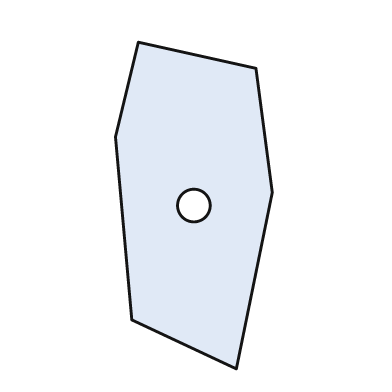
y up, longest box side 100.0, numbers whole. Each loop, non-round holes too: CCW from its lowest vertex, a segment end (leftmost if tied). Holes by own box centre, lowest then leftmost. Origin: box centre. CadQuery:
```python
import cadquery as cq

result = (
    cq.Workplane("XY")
    .moveTo(13.0, -50.0)
    .lineTo(24.0, 4.0)
    .lineTo(19.0, 42.0)
    .lineTo(-17.0, 50.0)
    .lineTo(-24.0, 21.0)
    .lineTo(-19.0, -35.0)
    .close()
    .moveTo(0.0, 0.0)
    .circle(5.0)
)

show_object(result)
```